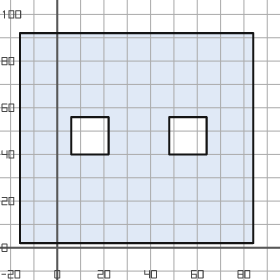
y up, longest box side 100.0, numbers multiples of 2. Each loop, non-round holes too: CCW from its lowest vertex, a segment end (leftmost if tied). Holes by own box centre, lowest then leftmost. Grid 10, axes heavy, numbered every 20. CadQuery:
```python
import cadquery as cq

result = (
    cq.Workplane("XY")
    .moveTo(-16.0, 2.0)
    .lineTo(84.0, 2.0)
    .lineTo(84.0, 92.0)
    .lineTo(-16.0, 92.0)
    .close()
    .moveTo(6.0, 40.0)
    .lineTo(22.0, 40.0)
    .lineTo(22.0, 56.0)
    .lineTo(6.0, 56.0)
    .close()
    .moveTo(48.0, 40.0)
    .lineTo(64.0, 40.0)
    .lineTo(64.0, 56.0)
    .lineTo(48.0, 56.0)
    .close()
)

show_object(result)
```